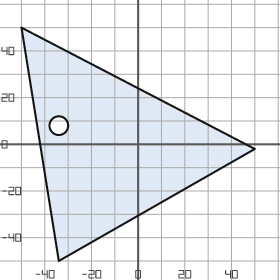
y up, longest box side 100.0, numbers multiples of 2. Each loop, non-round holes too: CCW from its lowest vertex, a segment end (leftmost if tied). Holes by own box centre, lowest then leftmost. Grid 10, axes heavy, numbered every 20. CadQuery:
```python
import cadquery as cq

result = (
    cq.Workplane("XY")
    .moveTo(-34.0, -50.0)
    .lineTo(50.0, -2.0)
    .lineTo(-50.0, 50.0)
    .close()
    .moveTo(-34.0, 8.0)
    .circle(4.0)
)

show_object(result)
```